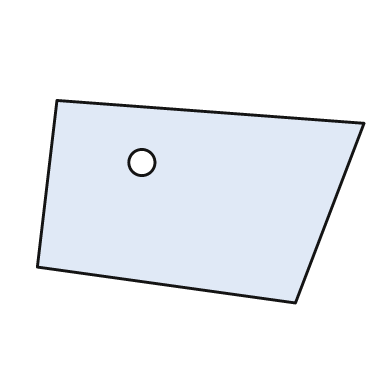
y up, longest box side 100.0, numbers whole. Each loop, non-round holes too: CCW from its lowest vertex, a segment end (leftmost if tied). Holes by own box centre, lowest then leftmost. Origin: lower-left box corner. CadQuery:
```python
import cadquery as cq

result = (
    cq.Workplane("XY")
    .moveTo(79.0, 0.0)
    .lineTo(100.0, 55.0)
    .lineTo(6.0, 62.0)
    .lineTo(0.0, 11.0)
    .close()
    .moveTo(32.0, 43.0)
    .circle(4.0)
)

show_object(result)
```